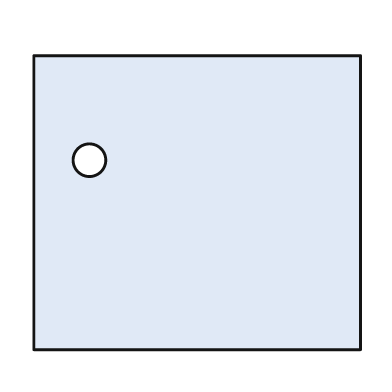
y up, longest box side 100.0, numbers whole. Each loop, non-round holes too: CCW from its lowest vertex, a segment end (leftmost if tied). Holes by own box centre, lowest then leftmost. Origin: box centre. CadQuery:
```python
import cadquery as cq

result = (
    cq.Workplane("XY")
    .moveTo(-50.0, -45.0)
    .lineTo(50.0, -45.0)
    .lineTo(50.0, 45.0)
    .lineTo(-50.0, 45.0)
    .close()
    .moveTo(-33.0, 13.0)
    .circle(5.0)
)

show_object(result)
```